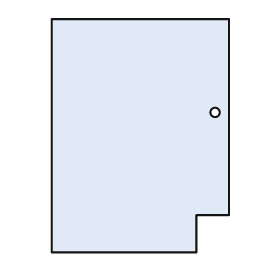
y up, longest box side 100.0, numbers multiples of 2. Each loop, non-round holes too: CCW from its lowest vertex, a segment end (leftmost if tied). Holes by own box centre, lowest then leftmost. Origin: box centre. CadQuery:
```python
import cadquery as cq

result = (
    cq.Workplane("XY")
    .moveTo(-38.0, -50.0)
    .lineTo(24.0, -50.0)
    .lineTo(24.0, -34.0)
    .lineTo(38.0, -34.0)
    .lineTo(38.0, 50.0)
    .lineTo(-38.0, 50.0)
    .close()
    .moveTo(32.0, 10.0)
    .circle(2.0)
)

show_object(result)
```